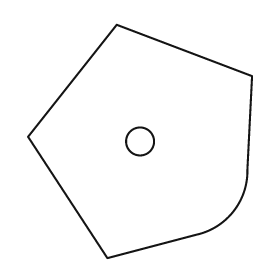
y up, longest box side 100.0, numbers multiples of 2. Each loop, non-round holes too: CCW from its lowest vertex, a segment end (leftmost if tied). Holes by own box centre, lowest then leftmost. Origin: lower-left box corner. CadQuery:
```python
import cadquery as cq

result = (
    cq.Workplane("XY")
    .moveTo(34.0, 0.0)
    .lineTo(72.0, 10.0)
    .threePointArc((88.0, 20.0), (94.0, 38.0))
    .lineTo(96.0, 78.0)
    .lineTo(38.0, 100.0)
    .lineTo(0.0, 52.0)
    .close()
    .moveTo(48.0, 50.0)
    .circle(6.0)
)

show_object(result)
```